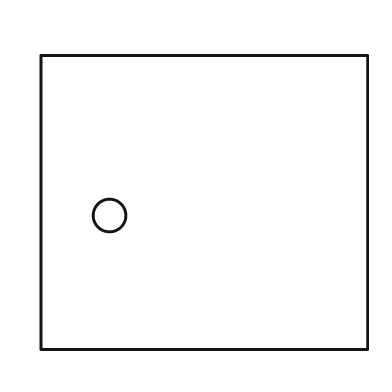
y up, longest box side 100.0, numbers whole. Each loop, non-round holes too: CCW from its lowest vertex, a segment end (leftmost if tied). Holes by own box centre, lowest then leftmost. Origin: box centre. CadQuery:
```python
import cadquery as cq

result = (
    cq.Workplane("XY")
    .moveTo(-50.0, -45.0)
    .lineTo(50.0, -45.0)
    .lineTo(50.0, 45.0)
    .lineTo(-50.0, 45.0)
    .close()
    .moveTo(-29.0, -4.0)
    .circle(5.0)
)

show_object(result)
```